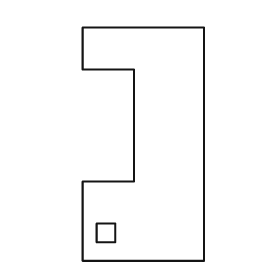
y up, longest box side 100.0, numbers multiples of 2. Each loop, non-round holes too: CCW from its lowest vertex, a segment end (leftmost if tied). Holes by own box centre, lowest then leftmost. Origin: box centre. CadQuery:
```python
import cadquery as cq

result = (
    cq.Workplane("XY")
    .moveTo(-26.0, -50.0)
    .lineTo(26.0, -50.0)
    .lineTo(26.0, 50.0)
    .lineTo(-26.0, 50.0)
    .lineTo(-26.0, 32.0)
    .lineTo(-4.0, 32.0)
    .lineTo(-4.0, -16.0)
    .lineTo(-26.0, -16.0)
    .close()
    .moveTo(-20.0, -42.0)
    .lineTo(-12.0, -42.0)
    .lineTo(-12.0, -34.0)
    .lineTo(-20.0, -34.0)
    .close()
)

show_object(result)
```